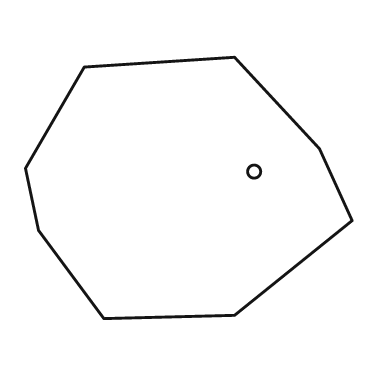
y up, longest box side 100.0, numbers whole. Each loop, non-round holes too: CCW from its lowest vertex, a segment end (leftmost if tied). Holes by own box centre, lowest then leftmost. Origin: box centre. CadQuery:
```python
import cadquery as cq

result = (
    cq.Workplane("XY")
    .moveTo(-26.0, -40.0)
    .lineTo(14.0, -39.0)
    .lineTo(50.0, -10.0)
    .lineTo(40.0, 12.0)
    .lineTo(14.0, 40.0)
    .lineTo(-32.0, 37.0)
    .lineTo(-50.0, 6.0)
    .lineTo(-46.0, -13.0)
    .close()
    .moveTo(20.0, 5.0)
    .circle(2.0)
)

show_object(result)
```